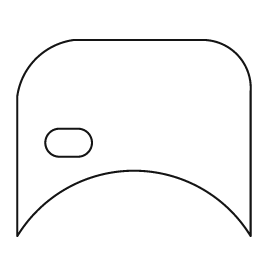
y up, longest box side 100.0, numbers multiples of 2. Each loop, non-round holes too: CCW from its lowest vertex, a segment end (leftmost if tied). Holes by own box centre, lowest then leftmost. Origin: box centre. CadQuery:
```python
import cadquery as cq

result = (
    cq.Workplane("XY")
    .moveTo(-50.0, -42.0)
    .threePointArc((0.0, -14.0), (50.0, -42.0))
    .lineTo(50.0, 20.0)
    .threePointArc((44.0, 36.0), (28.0, 42.0))
    .lineTo(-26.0, 42.0)
    .threePointArc((-42.0, 34.0), (-50.0, 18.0))
    .close()
    .moveTo(-32.0, -8.0)
    .lineTo(-24.0, -8.0)
    .threePointArc((-18.0, -2.0), (-24.0, 4.0))
    .lineTo(-32.0, 4.0)
    .threePointArc((-38.0, -2.0), (-32.0, -8.0))
    .close()
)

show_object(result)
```